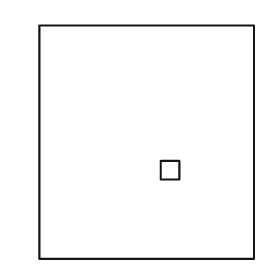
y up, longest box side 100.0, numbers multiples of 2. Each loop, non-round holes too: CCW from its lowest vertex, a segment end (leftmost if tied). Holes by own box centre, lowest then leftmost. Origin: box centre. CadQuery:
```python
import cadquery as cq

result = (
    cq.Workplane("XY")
    .moveTo(-46.0, -50.0)
    .lineTo(46.0, -50.0)
    .lineTo(46.0, 50.0)
    .lineTo(-46.0, 50.0)
    .close()
    .moveTo(6.0, -16.0)
    .lineTo(14.0, -16.0)
    .lineTo(14.0, -8.0)
    .lineTo(6.0, -8.0)
    .close()
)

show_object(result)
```